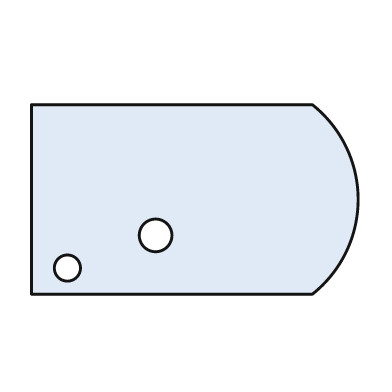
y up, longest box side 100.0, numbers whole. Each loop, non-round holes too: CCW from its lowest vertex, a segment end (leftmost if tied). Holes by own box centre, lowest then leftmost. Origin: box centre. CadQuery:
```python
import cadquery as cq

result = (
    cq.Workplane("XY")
    .moveTo(-50.0, -29.0)
    .lineTo(36.0, -29.0)
    .threePointArc((50.0, 0.0), (36.0, 29.0))
    .lineTo(-50.0, 29.0)
    .close()
    .moveTo(-39.0, -21.0)
    .circle(4.0)
    .moveTo(-12.0, -11.0)
    .circle(5.0)
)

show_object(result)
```